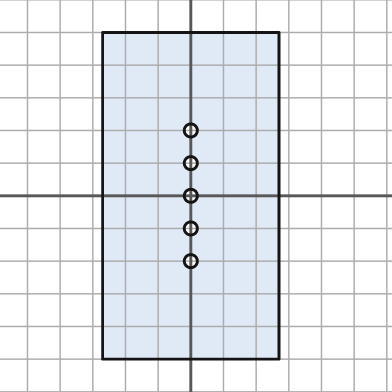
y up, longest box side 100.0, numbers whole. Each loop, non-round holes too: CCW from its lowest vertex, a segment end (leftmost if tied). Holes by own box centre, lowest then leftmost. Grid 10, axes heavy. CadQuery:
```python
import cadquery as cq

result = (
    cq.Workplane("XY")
    .moveTo(-27.0, -50.0)
    .lineTo(27.0, -50.0)
    .lineTo(27.0, 50.0)
    .lineTo(-27.0, 50.0)
    .close()
    .moveTo(0.0, -20.0)
    .circle(2.0)
    .moveTo(0.0, -10.0)
    .circle(2.0)
    .moveTo(0.0, 0.0)
    .circle(2.0)
    .moveTo(0.0, 10.0)
    .circle(2.0)
    .moveTo(0.0, 20.0)
    .circle(2.0)
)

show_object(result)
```